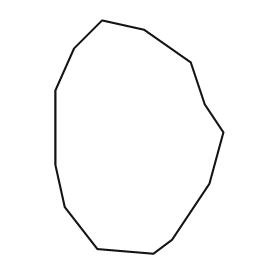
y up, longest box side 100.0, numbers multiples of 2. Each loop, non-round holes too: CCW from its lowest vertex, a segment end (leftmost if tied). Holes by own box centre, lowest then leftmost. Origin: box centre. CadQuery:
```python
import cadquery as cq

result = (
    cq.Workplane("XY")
    .moveTo(6.0, -50.0)
    .lineTo(14.0, -44.0)
    .lineTo(30.0, -20.0)
    .lineTo(36.0, 2.0)
    .lineTo(28.0, 14.0)
    .lineTo(22.0, 32.0)
    .lineTo(2.0, 46.0)
    .lineTo(-16.0, 50.0)
    .lineTo(-28.0, 38.0)
    .lineTo(-36.0, 20.0)
    .lineTo(-36.0, -12.0)
    .lineTo(-32.0, -30.0)
    .lineTo(-18.0, -48.0)
    .close()
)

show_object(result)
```